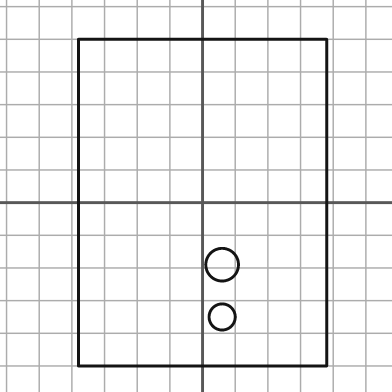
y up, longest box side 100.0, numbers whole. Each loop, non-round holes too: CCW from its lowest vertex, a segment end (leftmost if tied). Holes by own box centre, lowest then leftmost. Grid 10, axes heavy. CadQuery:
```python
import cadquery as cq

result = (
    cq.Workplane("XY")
    .moveTo(-38.0, -50.0)
    .lineTo(38.0, -50.0)
    .lineTo(38.0, 50.0)
    .lineTo(-38.0, 50.0)
    .close()
    .moveTo(6.0, -35.0)
    .circle(4.0)
    .moveTo(6.0, -19.0)
    .circle(5.0)
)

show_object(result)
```